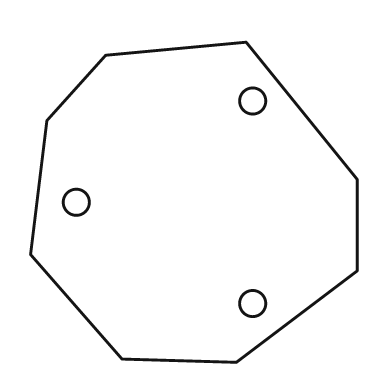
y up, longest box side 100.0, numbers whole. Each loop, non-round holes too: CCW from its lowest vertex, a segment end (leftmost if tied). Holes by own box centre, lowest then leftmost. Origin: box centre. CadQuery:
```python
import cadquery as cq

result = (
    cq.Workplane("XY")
    .moveTo(13.0, -49.0)
    .lineTo(50.0, -21.0)
    .lineTo(50.0, 7.0)
    .lineTo(16.0, 49.0)
    .lineTo(-27.0, 45.0)
    .lineTo(-45.0, 25.0)
    .lineTo(-50.0, -16.0)
    .lineTo(-22.0, -48.0)
    .close()
    .moveTo(18.0, -31.0)
    .circle(4.0)
    .moveTo(-36.0, 0.0)
    .circle(4.0)
    .moveTo(18.0, 31.0)
    .circle(4.0)
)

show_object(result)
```